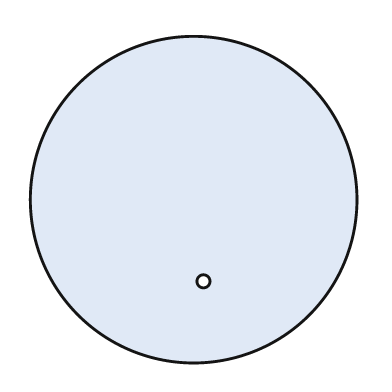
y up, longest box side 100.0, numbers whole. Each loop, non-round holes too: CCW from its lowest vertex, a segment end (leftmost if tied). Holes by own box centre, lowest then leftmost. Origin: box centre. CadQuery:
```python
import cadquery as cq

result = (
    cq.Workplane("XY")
    .moveTo(0.0, 0.0)
    .circle(50.0)
    .moveTo(3.0, -25.0)
    .circle(2.0)
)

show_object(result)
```